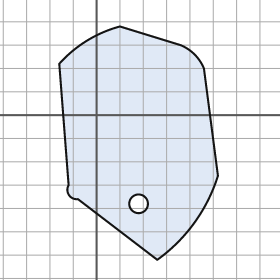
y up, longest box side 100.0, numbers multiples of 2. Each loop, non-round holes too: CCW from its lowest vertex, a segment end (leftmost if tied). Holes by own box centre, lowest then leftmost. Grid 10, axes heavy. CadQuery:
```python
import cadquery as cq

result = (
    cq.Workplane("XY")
    .moveTo(26.0, -62.0)
    .threePointArc((42.0, -46.0), (52.0, -26.0))
    .lineTo(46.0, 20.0)
    .threePointArc((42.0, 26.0), (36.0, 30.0))
    .lineTo(10.0, 38.0)
    .threePointArc((-4.0, 32.0), (-16.0, 22.0))
    .lineTo(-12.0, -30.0)
    .threePointArc((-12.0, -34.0), (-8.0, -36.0))
    .close()
    .moveTo(18.0, -38.0)
    .circle(4.0)
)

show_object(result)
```